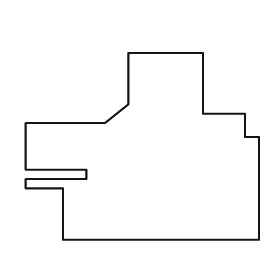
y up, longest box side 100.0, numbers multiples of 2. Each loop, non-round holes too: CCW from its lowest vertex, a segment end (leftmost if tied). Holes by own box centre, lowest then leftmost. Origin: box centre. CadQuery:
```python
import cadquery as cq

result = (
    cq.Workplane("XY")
    .moveTo(-34.0, -40.0)
    .lineTo(50.0, -40.0)
    .lineTo(50.0, 4.0)
    .lineTo(44.0, 4.0)
    .lineTo(44.0, 14.0)
    .lineTo(26.0, 14.0)
    .lineTo(26.0, 40.0)
    .lineTo(-6.0, 40.0)
    .lineTo(-6.0, 18.0)
    .lineTo(-16.0, 10.0)
    .lineTo(-50.0, 10.0)
    .lineTo(-50.0, -10.0)
    .lineTo(-24.0, -10.0)
    .lineTo(-24.0, -14.0)
    .lineTo(-50.0, -14.0)
    .lineTo(-50.0, -18.0)
    .lineTo(-34.0, -18.0)
    .close()
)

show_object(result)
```